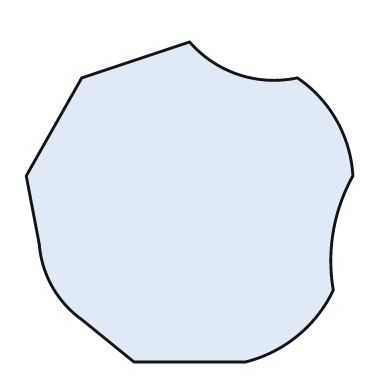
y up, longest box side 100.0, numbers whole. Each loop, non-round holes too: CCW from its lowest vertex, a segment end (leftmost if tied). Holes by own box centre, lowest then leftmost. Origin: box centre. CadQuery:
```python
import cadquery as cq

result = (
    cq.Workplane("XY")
    .moveTo(-17.0, -49.0)
    .lineTo(17.0, -49.0)
    .threePointArc((33.0, -41.0), (44.0, -27.0))
    .threePointArc((44.0, -9.0), (50.0, 8.0))
    .threePointArc((45.0, 25.0), (33.0, 38.0))
    .threePointArc((15.0, 39.0), (0.0, 49.0))
    .lineTo(-33.0, 38.0)
    .lineTo(-50.0, 8.0)
    .lineTo(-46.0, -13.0)
    .threePointArc((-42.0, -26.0), (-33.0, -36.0))
    .close()
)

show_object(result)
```